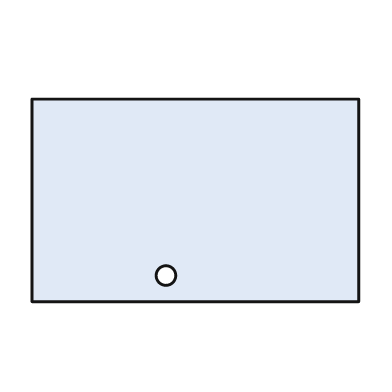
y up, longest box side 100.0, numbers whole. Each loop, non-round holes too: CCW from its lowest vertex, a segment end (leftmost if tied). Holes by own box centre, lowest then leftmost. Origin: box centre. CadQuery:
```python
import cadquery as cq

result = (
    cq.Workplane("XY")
    .moveTo(-50.0, -31.0)
    .lineTo(50.0, -31.0)
    .lineTo(50.0, 31.0)
    .lineTo(-50.0, 31.0)
    .close()
    .moveTo(-9.0, -23.0)
    .circle(3.0)
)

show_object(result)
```